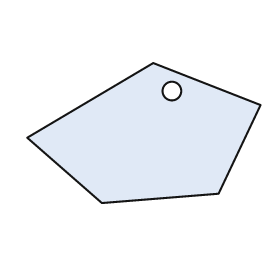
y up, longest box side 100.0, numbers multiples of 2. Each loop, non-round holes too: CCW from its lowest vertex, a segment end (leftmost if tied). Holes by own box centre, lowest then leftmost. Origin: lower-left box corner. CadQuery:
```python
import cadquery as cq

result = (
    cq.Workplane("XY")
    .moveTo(32.0, 0.0)
    .lineTo(82.0, 4.0)
    .lineTo(100.0, 42.0)
    .lineTo(54.0, 60.0)
    .lineTo(0.0, 28.0)
    .close()
    .moveTo(62.0, 48.0)
    .circle(4.0)
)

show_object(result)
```